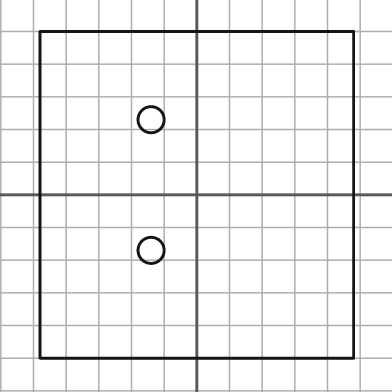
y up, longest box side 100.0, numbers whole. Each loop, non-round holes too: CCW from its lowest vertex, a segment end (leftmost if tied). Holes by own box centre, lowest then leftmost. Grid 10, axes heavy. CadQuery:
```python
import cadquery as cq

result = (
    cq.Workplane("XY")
    .moveTo(-48.0, -50.0)
    .lineTo(48.0, -50.0)
    .lineTo(48.0, 50.0)
    .lineTo(-48.0, 50.0)
    .close()
    .moveTo(-14.0, -17.0)
    .circle(4.0)
    .moveTo(-14.0, 23.0)
    .circle(4.0)
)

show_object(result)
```